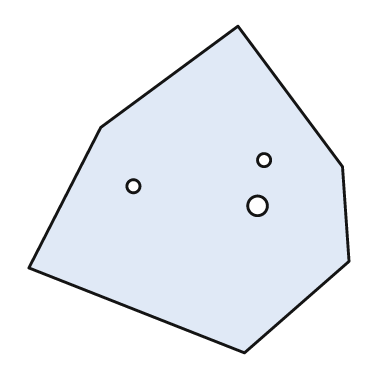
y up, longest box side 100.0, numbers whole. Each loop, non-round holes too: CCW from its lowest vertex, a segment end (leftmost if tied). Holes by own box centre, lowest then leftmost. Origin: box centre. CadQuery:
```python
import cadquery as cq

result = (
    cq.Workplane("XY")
    .moveTo(17.0, -50.0)
    .lineTo(49.0, -22.0)
    .lineTo(47.0, 7.0)
    .lineTo(15.0, 50.0)
    .lineTo(-27.0, 19.0)
    .lineTo(-49.0, -24.0)
    .close()
    .moveTo(21.0, -5.0)
    .circle(3.0)
    .moveTo(-17.0, 1.0)
    .circle(2.0)
    .moveTo(23.0, 9.0)
    .circle(2.0)
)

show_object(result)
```